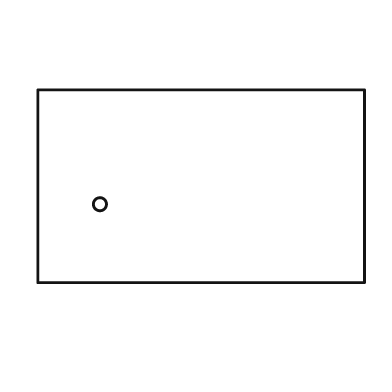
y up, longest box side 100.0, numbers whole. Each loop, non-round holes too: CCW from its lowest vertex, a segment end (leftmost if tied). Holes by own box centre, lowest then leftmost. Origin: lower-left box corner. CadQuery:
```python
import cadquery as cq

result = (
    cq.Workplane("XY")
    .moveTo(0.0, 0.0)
    .lineTo(100.0, 0.0)
    .lineTo(100.0, 59.0)
    .lineTo(0.0, 59.0)
    .close()
    .moveTo(19.0, 24.0)
    .circle(2.0)
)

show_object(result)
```